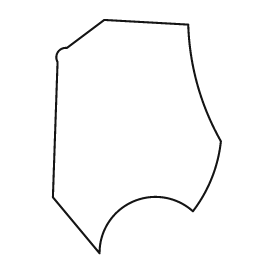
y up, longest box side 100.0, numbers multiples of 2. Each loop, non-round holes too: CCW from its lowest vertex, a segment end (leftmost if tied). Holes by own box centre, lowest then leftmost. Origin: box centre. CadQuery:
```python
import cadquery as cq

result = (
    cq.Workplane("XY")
    .moveTo(-16.0, -50.0)
    .threePointArc((-2.0, -28.0), (24.0, -32.0))
    .threePointArc((32.0, -18.0), (36.0, -2.0))
    .threePointArc((26.0, 22.0), (22.0, 48.0))
    .lineTo(-14.0, 50.0)
    .lineTo(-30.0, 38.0)
    .threePointArc((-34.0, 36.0), (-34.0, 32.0))
    .lineTo(-36.0, -26.0)
    .close()
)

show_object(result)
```